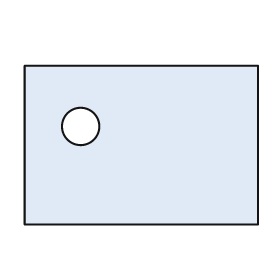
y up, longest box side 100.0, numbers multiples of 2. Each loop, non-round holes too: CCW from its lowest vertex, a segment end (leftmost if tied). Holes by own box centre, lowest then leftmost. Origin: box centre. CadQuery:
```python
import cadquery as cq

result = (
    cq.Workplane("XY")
    .moveTo(-50.0, -34.0)
    .lineTo(50.0, -34.0)
    .lineTo(50.0, 34.0)
    .lineTo(-50.0, 34.0)
    .close()
    .moveTo(-26.0, 8.0)
    .circle(8.0)
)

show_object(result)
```